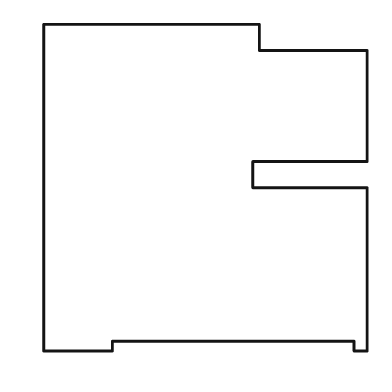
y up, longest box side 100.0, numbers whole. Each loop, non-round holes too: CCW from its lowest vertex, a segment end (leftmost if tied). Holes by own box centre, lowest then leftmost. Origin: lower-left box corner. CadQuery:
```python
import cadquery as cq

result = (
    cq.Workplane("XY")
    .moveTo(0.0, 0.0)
    .lineTo(21.0, 0.0)
    .lineTo(21.0, 3.0)
    .lineTo(95.0, 3.0)
    .lineTo(95.0, 0.0)
    .lineTo(99.0, 0.0)
    .lineTo(99.0, 50.0)
    .lineTo(64.0, 50.0)
    .lineTo(64.0, 58.0)
    .lineTo(99.0, 58.0)
    .lineTo(99.0, 92.0)
    .lineTo(66.0, 92.0)
    .lineTo(66.0, 100.0)
    .lineTo(0.0, 100.0)
    .close()
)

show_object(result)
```